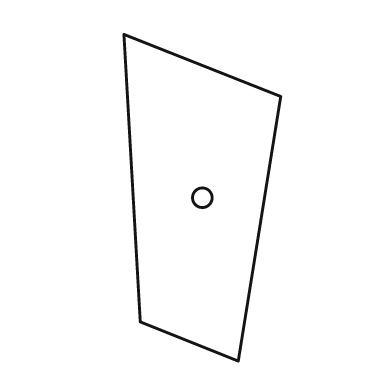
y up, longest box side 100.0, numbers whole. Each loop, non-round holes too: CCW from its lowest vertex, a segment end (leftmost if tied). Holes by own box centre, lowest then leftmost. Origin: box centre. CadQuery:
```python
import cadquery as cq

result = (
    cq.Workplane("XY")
    .moveTo(11.0, -50.0)
    .lineTo(24.0, 31.0)
    .lineTo(-24.0, 50.0)
    .lineTo(-19.0, -38.0)
    .close()
    .moveTo(0.0, 0.0)
    .circle(3.0)
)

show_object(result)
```